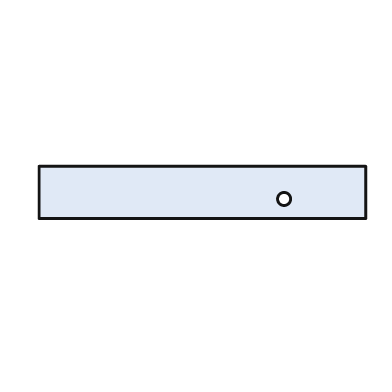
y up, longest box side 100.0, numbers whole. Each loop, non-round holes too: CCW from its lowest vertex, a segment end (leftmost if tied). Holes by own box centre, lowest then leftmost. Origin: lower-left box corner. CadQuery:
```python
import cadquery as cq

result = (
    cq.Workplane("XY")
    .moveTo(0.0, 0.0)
    .lineTo(100.0, 0.0)
    .lineTo(100.0, 16.0)
    .lineTo(0.0, 16.0)
    .close()
    .moveTo(75.0, 6.0)
    .circle(2.0)
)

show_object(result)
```